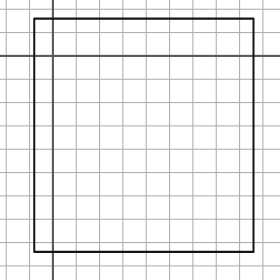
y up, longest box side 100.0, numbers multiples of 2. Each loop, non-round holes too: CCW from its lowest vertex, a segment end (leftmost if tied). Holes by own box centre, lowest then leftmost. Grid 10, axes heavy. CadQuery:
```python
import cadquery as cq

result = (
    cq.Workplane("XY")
    .moveTo(-8.0, -84.0)
    .lineTo(86.0, -84.0)
    .lineTo(86.0, 16.0)
    .lineTo(-8.0, 16.0)
    .close()
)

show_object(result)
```